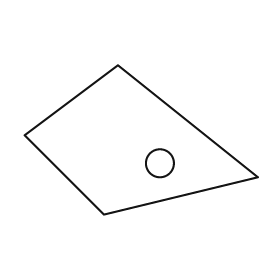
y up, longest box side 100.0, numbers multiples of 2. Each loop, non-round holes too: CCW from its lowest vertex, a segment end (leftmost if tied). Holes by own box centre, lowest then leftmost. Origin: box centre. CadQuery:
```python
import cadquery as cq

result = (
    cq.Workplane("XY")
    .moveTo(-16.0, -32.0)
    .lineTo(50.0, -16.0)
    .lineTo(-10.0, 32.0)
    .lineTo(-50.0, 2.0)
    .close()
    .moveTo(8.0, -10.0)
    .circle(6.0)
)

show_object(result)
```